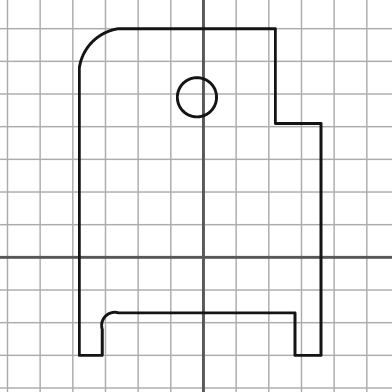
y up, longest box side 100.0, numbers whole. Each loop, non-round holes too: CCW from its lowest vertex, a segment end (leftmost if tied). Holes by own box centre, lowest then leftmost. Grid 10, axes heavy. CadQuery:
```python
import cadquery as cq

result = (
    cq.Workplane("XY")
    .moveTo(-38.0, -30.0)
    .lineTo(-31.0, -30.0)
    .lineTo(-31.0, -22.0)
    .threePointArc((-30.0, -18.0), (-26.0, -17.0))
    .lineTo(28.0, -17.0)
    .lineTo(28.0, -30.0)
    .lineTo(36.0, -30.0)
    .lineTo(36.0, 41.0)
    .lineTo(22.0, 41.0)
    .lineTo(22.0, 70.0)
    .lineTo(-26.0, 70.0)
    .threePointArc((-34.0, 66.0), (-38.0, 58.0))
    .close()
    .moveTo(-2.0, 49.0)
    .circle(6.0)
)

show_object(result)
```